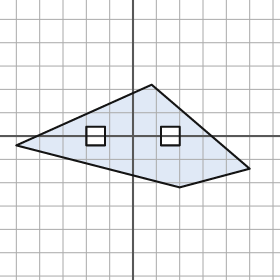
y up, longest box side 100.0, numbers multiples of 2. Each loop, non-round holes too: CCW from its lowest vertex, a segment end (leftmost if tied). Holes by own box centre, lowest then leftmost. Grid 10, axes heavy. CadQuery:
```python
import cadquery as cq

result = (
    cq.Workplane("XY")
    .moveTo(20.0, -22.0)
    .lineTo(50.0, -14.0)
    .lineTo(8.0, 22.0)
    .lineTo(-50.0, -4.0)
    .close()
    .moveTo(-20.0, -4.0)
    .lineTo(-12.0, -4.0)
    .lineTo(-12.0, 4.0)
    .lineTo(-20.0, 4.0)
    .close()
    .moveTo(12.0, -4.0)
    .lineTo(20.0, -4.0)
    .lineTo(20.0, 4.0)
    .lineTo(12.0, 4.0)
    .close()
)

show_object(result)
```